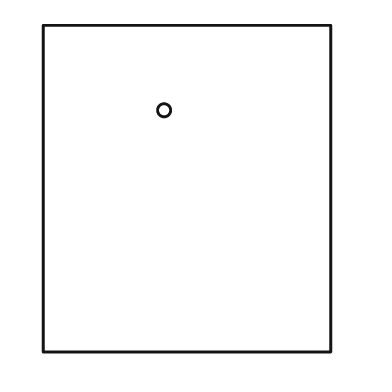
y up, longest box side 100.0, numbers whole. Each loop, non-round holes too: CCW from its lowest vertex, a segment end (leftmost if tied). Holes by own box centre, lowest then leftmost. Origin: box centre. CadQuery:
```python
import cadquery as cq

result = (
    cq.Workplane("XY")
    .moveTo(-44.0, -50.0)
    .lineTo(44.0, -50.0)
    .lineTo(44.0, 50.0)
    .lineTo(-44.0, 50.0)
    .close()
    .moveTo(-7.0, 24.0)
    .circle(2.0)
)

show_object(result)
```